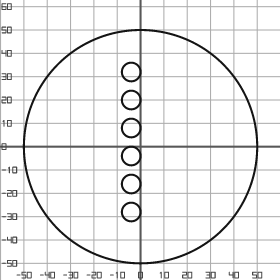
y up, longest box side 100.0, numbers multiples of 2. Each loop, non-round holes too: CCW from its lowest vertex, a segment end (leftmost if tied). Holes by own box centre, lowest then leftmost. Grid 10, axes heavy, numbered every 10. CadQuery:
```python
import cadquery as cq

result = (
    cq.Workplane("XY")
    .moveTo(0.0, 0.0)
    .circle(50.0)
    .moveTo(-4.0, -28.0)
    .circle(4.0)
    .moveTo(-4.0, -16.0)
    .circle(4.0)
    .moveTo(-4.0, -4.0)
    .circle(4.0)
    .moveTo(-4.0, 8.0)
    .circle(4.0)
    .moveTo(-4.0, 20.0)
    .circle(4.0)
    .moveTo(-4.0, 32.0)
    .circle(4.0)
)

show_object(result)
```